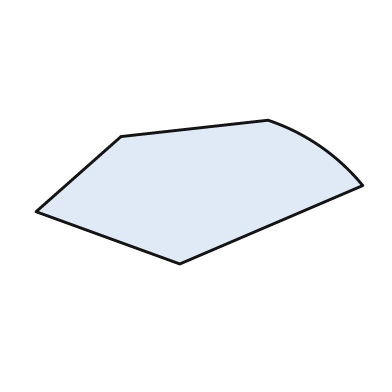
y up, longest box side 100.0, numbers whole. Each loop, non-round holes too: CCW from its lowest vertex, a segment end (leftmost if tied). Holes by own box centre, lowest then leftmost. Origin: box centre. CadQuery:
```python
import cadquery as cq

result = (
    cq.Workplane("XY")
    .moveTo(-6.0, -22.0)
    .lineTo(50.0, 2.0)
    .threePointArc((37.0, 14.0), (21.0, 22.0))
    .lineTo(-24.0, 17.0)
    .lineTo(-50.0, -6.0)
    .close()
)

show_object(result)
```